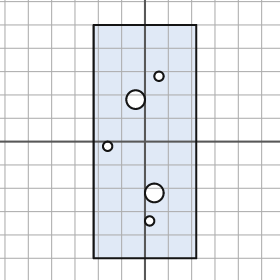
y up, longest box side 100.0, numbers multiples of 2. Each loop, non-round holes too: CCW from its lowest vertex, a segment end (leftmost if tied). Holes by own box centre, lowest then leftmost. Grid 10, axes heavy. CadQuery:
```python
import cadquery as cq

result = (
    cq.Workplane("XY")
    .moveTo(-22.0, -50.0)
    .lineTo(22.0, -50.0)
    .lineTo(22.0, 50.0)
    .lineTo(-22.0, 50.0)
    .close()
    .moveTo(2.0, -34.0)
    .circle(2.0)
    .moveTo(4.0, -22.0)
    .circle(4.0)
    .moveTo(-16.0, -2.0)
    .circle(2.0)
    .moveTo(-4.0, 18.0)
    .circle(4.0)
    .moveTo(6.0, 28.0)
    .circle(2.0)
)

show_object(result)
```